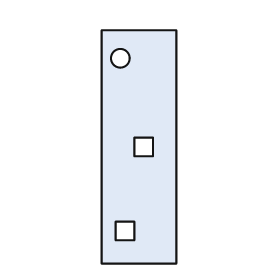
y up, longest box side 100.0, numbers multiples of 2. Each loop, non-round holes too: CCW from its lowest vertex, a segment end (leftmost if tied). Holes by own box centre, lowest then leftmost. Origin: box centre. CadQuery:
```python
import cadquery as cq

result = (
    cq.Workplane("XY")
    .moveTo(-16.0, -50.0)
    .lineTo(16.0, -50.0)
    .lineTo(16.0, 50.0)
    .lineTo(-16.0, 50.0)
    .close()
    .moveTo(-10.0, -40.0)
    .lineTo(-2.0, -40.0)
    .lineTo(-2.0, -32.0)
    .lineTo(-10.0, -32.0)
    .close()
    .moveTo(-2.0, -4.0)
    .lineTo(6.0, -4.0)
    .lineTo(6.0, 4.0)
    .lineTo(-2.0, 4.0)
    .close()
    .moveTo(-8.0, 38.0)
    .circle(4.0)
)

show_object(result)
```